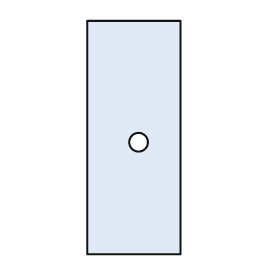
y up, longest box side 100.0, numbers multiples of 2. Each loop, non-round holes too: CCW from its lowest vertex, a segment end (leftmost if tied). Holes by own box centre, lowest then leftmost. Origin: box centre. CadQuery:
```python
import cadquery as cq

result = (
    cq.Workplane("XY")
    .moveTo(-20.0, -50.0)
    .lineTo(20.0, -50.0)
    .lineTo(20.0, 50.0)
    .lineTo(-20.0, 50.0)
    .close()
    .moveTo(2.0, -2.0)
    .circle(4.0)
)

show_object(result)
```